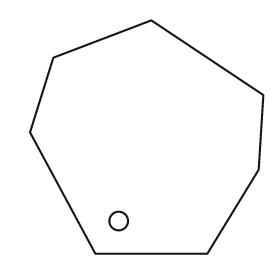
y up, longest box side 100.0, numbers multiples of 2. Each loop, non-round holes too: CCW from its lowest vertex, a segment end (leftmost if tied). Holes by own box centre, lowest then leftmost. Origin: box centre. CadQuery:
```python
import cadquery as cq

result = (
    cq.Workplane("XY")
    .moveTo(-22.0, -50.0)
    .lineTo(26.0, -50.0)
    .lineTo(48.0, -14.0)
    .lineTo(50.0, 18.0)
    .lineTo(2.0, 50.0)
    .lineTo(-40.0, 34.0)
    .lineTo(-50.0, 2.0)
    .close()
    .moveTo(-12.0, -36.0)
    .circle(4.0)
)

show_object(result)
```